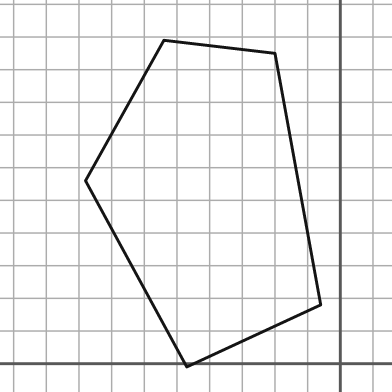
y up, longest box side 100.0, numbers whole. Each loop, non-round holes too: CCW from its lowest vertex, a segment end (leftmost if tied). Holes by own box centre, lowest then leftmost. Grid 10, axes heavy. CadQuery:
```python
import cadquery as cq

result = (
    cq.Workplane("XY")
    .moveTo(-47.0, -1.0)
    .lineTo(-6.0, 18.0)
    .lineTo(-20.0, 95.0)
    .lineTo(-54.0, 99.0)
    .lineTo(-78.0, 56.0)
    .close()
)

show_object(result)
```